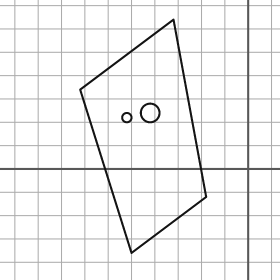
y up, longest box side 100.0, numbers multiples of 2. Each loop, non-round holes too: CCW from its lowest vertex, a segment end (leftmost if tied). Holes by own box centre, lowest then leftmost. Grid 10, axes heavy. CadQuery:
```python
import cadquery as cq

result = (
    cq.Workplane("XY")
    .moveTo(-50.0, -36.0)
    .lineTo(-18.0, -12.0)
    .lineTo(-32.0, 64.0)
    .lineTo(-72.0, 34.0)
    .close()
    .moveTo(-52.0, 22.0)
    .circle(2.0)
    .moveTo(-42.0, 24.0)
    .circle(4.0)
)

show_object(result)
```